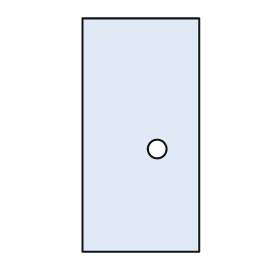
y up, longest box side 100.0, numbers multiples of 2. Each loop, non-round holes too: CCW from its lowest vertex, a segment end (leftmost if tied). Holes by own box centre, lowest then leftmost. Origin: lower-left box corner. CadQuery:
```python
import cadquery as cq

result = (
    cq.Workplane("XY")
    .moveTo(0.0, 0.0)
    .lineTo(50.0, 0.0)
    .lineTo(50.0, 100.0)
    .lineTo(0.0, 100.0)
    .close()
    .moveTo(32.0, 44.0)
    .circle(4.0)
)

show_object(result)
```